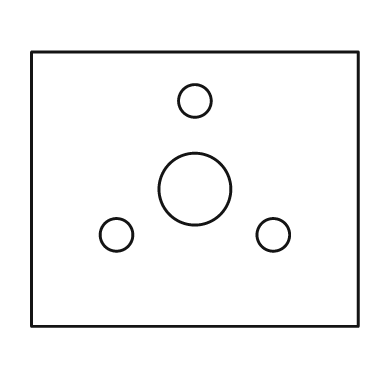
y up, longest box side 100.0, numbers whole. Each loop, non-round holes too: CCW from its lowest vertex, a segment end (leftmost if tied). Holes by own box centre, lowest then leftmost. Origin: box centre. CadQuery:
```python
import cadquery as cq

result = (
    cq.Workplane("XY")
    .moveTo(-50.0, -42.0)
    .lineTo(50.0, -42.0)
    .lineTo(50.0, 42.0)
    .lineTo(-50.0, 42.0)
    .close()
    .moveTo(-24.0, -14.0)
    .circle(5.0)
    .moveTo(24.0, -14.0)
    .circle(5.0)
    .moveTo(0.0, 0.0)
    .circle(11.0)
    .moveTo(0.0, 27.0)
    .circle(5.0)
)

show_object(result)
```